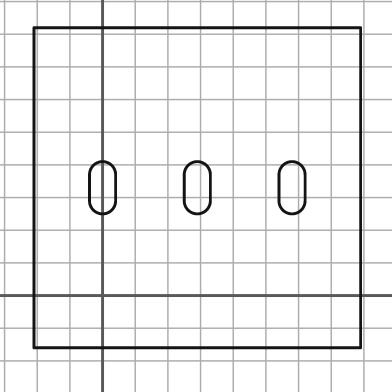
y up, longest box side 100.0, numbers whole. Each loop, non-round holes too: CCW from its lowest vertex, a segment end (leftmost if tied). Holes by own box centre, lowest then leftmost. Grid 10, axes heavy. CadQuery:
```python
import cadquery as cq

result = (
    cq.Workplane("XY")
    .moveTo(-21.0, -16.0)
    .lineTo(79.0, -16.0)
    .lineTo(79.0, 82.0)
    .lineTo(-21.0, 82.0)
    .close()
    .moveTo(-4.0, 29.0)
    .threePointArc((0.0, 25.0), (4.0, 29.0))
    .lineTo(4.0, 37.0)
    .threePointArc((0.0, 41.0), (-4.0, 37.0))
    .close()
    .moveTo(25.0, 29.0)
    .threePointArc((29.0, 25.0), (33.0, 29.0))
    .lineTo(33.0, 37.0)
    .threePointArc((29.0, 41.0), (25.0, 37.0))
    .close()
    .moveTo(54.0, 29.0)
    .threePointArc((58.0, 25.0), (62.0, 29.0))
    .lineTo(62.0, 37.0)
    .threePointArc((58.0, 41.0), (54.0, 37.0))
    .close()
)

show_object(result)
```